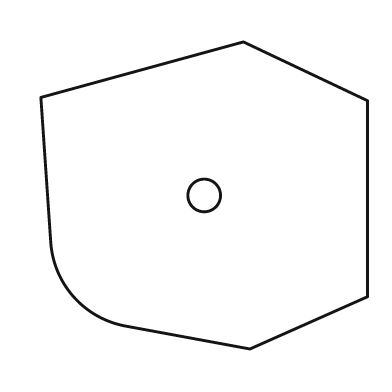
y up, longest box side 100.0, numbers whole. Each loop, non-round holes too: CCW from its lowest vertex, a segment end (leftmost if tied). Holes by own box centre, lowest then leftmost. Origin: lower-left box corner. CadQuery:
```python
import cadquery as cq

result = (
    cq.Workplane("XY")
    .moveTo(64.0, 0.0)
    .lineTo(100.0, 16.0)
    .lineTo(100.0, 76.0)
    .lineTo(62.0, 94.0)
    .lineTo(0.0, 77.0)
    .lineTo(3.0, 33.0)
    .threePointArc((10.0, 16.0), (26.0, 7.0))
    .close()
    .moveTo(50.0, 47.0)
    .circle(5.0)
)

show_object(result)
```